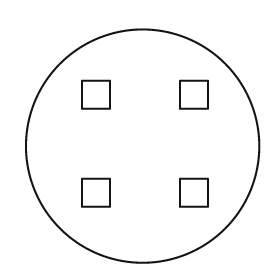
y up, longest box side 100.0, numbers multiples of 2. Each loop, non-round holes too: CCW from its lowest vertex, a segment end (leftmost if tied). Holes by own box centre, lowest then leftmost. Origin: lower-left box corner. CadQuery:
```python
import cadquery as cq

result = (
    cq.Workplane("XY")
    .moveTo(50.0, 50.0)
    .circle(50.0)
    .moveTo(24.0, 24.0)
    .lineTo(36.0, 24.0)
    .lineTo(36.0, 36.0)
    .lineTo(24.0, 36.0)
    .close()
    .moveTo(66.0, 24.0)
    .lineTo(78.0, 24.0)
    .lineTo(78.0, 36.0)
    .lineTo(66.0, 36.0)
    .close()
    .moveTo(24.0, 66.0)
    .lineTo(36.0, 66.0)
    .lineTo(36.0, 78.0)
    .lineTo(24.0, 78.0)
    .close()
    .moveTo(66.0, 66.0)
    .lineTo(78.0, 66.0)
    .lineTo(78.0, 78.0)
    .lineTo(66.0, 78.0)
    .close()
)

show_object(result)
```